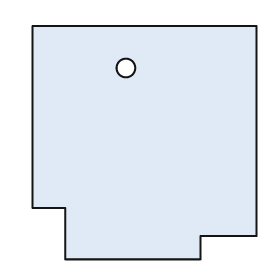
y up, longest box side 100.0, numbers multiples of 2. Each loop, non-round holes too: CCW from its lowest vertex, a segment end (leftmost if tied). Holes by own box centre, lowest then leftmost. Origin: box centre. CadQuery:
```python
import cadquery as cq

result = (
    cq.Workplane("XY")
    .moveTo(-34.0, -50.0)
    .lineTo(24.0, -50.0)
    .lineTo(24.0, -40.0)
    .lineTo(48.0, -40.0)
    .lineTo(48.0, 50.0)
    .lineTo(-48.0, 50.0)
    .lineTo(-48.0, -28.0)
    .lineTo(-34.0, -28.0)
    .close()
    .moveTo(-8.0, 32.0)
    .circle(4.0)
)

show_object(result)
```